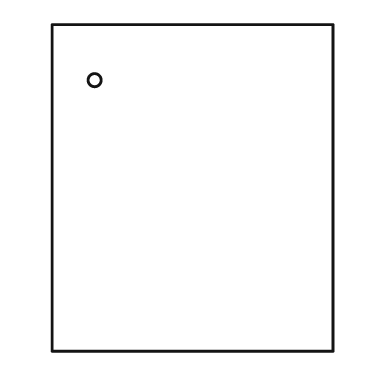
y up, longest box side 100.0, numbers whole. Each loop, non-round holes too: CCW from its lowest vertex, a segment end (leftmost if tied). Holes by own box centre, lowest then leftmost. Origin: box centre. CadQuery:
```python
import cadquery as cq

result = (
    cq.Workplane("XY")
    .moveTo(-43.0, -50.0)
    .lineTo(43.0, -50.0)
    .lineTo(43.0, 50.0)
    .lineTo(-43.0, 50.0)
    .close()
    .moveTo(-30.0, 33.0)
    .circle(2.0)
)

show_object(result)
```